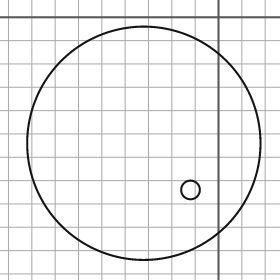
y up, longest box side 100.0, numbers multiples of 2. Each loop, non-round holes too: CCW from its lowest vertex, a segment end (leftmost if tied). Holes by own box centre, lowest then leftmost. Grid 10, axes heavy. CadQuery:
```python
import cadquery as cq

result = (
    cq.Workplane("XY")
    .moveTo(-32.0, -54.0)
    .circle(50.0)
    .moveTo(-12.0, -74.0)
    .circle(4.0)
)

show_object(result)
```